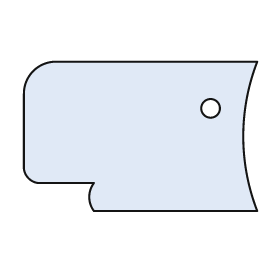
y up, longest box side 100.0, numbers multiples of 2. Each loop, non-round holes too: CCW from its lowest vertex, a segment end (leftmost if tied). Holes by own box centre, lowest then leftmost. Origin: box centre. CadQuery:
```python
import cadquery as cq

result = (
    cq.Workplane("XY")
    .moveTo(-20.0, -32.0)
    .lineTo(50.0, -32.0)
    .threePointArc((44.0, 0.0), (50.0, 32.0))
    .lineTo(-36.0, 32.0)
    .threePointArc((-46.0, 28.0), (-50.0, 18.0))
    .lineTo(-50.0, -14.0)
    .threePointArc((-48.0, -18.0), (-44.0, -20.0))
    .lineTo(-20.0, -20.0)
    .threePointArc((-22.0, -26.0), (-20.0, -32.0))
    .close()
    .moveTo(30.0, 12.0)
    .circle(4.0)
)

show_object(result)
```